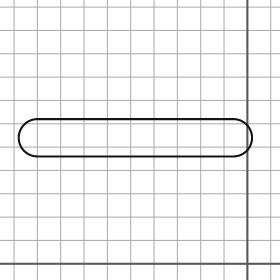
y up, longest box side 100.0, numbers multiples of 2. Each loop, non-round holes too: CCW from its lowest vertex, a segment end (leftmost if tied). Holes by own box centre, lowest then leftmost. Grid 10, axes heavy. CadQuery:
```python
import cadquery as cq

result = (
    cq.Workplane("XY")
    .moveTo(-90.0, 46.0)
    .lineTo(-6.0, 46.0)
    .threePointArc((2.0, 54.0), (-6.0, 62.0))
    .lineTo(-90.0, 62.0)
    .threePointArc((-98.0, 54.0), (-90.0, 46.0))
    .close()
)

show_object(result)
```